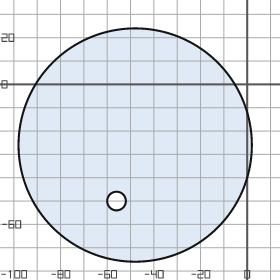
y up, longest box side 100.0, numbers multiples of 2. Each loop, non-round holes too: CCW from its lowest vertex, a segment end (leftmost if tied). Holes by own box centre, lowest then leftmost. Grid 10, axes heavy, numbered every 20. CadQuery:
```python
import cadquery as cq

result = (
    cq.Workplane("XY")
    .moveTo(-48.0, -26.0)
    .circle(50.0)
    .moveTo(-56.0, -50.0)
    .circle(4.0)
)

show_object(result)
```